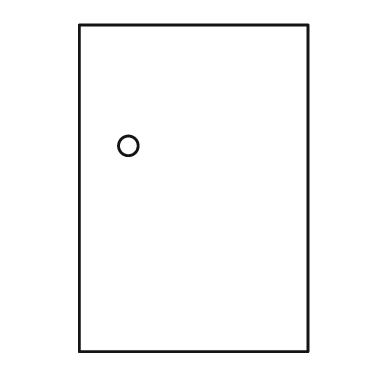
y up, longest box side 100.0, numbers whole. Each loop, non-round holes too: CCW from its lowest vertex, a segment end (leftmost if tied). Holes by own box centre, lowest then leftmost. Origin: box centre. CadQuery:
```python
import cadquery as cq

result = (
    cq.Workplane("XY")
    .moveTo(-35.0, -50.0)
    .lineTo(35.0, -50.0)
    .lineTo(35.0, 50.0)
    .lineTo(-35.0, 50.0)
    .close()
    .moveTo(-20.0, 13.0)
    .circle(3.0)
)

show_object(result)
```